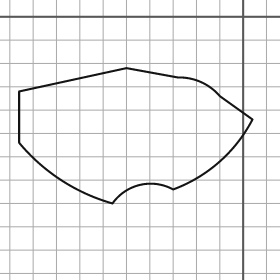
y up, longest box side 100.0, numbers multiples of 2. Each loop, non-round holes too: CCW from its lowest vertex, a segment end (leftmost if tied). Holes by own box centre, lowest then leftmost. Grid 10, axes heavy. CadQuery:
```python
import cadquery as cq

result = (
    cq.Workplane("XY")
    .moveTo(-56.0, -80.0)
    .threePointArc((-44.0, -72.0), (-30.0, -74.0))
    .threePointArc((-10.0, -62.0), (4.0, -44.0))
    .lineTo(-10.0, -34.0)
    .threePointArc((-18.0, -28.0), (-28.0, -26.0))
    .lineTo(-50.0, -22.0)
    .lineTo(-96.0, -32.0)
    .lineTo(-96.0, -54.0)
    .threePointArc((-78.0, -70.0), (-56.0, -80.0))
    .close()
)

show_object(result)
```